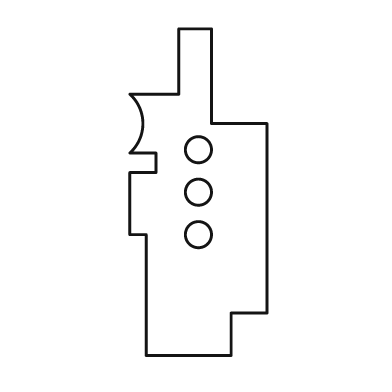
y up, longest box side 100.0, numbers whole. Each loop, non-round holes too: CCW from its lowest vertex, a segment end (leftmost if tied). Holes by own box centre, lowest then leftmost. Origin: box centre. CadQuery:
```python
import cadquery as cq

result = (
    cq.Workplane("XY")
    .moveTo(-16.0, -50.0)
    .lineTo(10.0, -50.0)
    .lineTo(10.0, -37.0)
    .lineTo(21.0, -37.0)
    .lineTo(21.0, 21.0)
    .lineTo(4.0, 21.0)
    .lineTo(4.0, 50.0)
    .lineTo(-6.0, 50.0)
    .lineTo(-6.0, 30.0)
    .lineTo(-21.0, 30.0)
    .threePointArc((-17.0, 21.0), (-21.0, 12.0))
    .lineTo(-13.0, 12.0)
    .lineTo(-13.0, 6.0)
    .lineTo(-21.0, 6.0)
    .lineTo(-21.0, -13.0)
    .lineTo(-16.0, -13.0)
    .close()
    .moveTo(0.0, -13.0)
    .circle(4.0)
    .moveTo(0.0, 0.0)
    .circle(4.0)
    .moveTo(0.0, 13.0)
    .circle(4.0)
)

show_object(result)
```